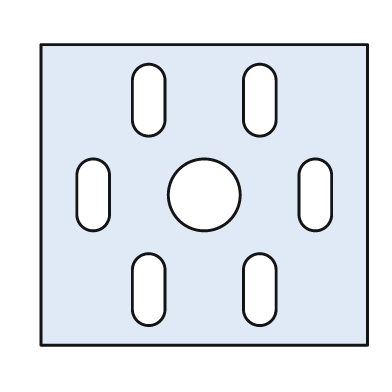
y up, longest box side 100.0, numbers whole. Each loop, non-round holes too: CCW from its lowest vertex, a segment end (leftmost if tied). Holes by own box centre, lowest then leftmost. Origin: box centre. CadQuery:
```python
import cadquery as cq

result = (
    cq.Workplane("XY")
    .moveTo(-50.0, -46.0)
    .lineTo(50.0, -46.0)
    .lineTo(50.0, 46.0)
    .lineTo(-50.0, 46.0)
    .close()
    .moveTo(-22.0, -35.0)
    .threePointArc((-17.0, -40.0), (-12.0, -35.0))
    .lineTo(-12.0, -23.0)
    .threePointArc((-17.0, -18.0), (-22.0, -23.0))
    .close()
    .moveTo(12.0, -35.0)
    .threePointArc((17.0, -40.0), (22.0, -35.0))
    .lineTo(22.0, -23.0)
    .threePointArc((17.0, -18.0), (12.0, -23.0))
    .close()
    .moveTo(-39.0, -6.0)
    .threePointArc((-34.0, -11.0), (-29.0, -6.0))
    .lineTo(-29.0, 6.0)
    .threePointArc((-34.0, 11.0), (-39.0, 6.0))
    .close()
    .moveTo(0.0, 0.0)
    .circle(11.0)
    .moveTo(29.0, -6.0)
    .threePointArc((34.0, -11.0), (39.0, -6.0))
    .lineTo(39.0, 6.0)
    .threePointArc((34.0, 11.0), (29.0, 6.0))
    .close()
    .moveTo(-22.0, 23.0)
    .threePointArc((-17.0, 18.0), (-12.0, 23.0))
    .lineTo(-12.0, 35.0)
    .threePointArc((-17.0, 40.0), (-22.0, 35.0))
    .close()
    .moveTo(12.0, 23.0)
    .threePointArc((17.0, 18.0), (22.0, 23.0))
    .lineTo(22.0, 35.0)
    .threePointArc((17.0, 40.0), (12.0, 35.0))
    .close()
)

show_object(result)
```